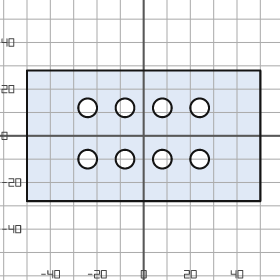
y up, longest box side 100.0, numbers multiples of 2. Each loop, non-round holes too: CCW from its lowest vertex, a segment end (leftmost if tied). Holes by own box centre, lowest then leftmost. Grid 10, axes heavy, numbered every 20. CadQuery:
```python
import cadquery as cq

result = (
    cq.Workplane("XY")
    .moveTo(-50.0, -28.0)
    .lineTo(50.0, -28.0)
    .lineTo(50.0, 28.0)
    .lineTo(-50.0, 28.0)
    .close()
    .moveTo(-24.0, -10.0)
    .circle(4.0)
    .moveTo(-8.0, -10.0)
    .circle(4.0)
    .moveTo(8.0, -10.0)
    .circle(4.0)
    .moveTo(24.0, -10.0)
    .circle(4.0)
    .moveTo(-24.0, 12.0)
    .circle(4.0)
    .moveTo(-8.0, 12.0)
    .circle(4.0)
    .moveTo(8.0, 12.0)
    .circle(4.0)
    .moveTo(24.0, 12.0)
    .circle(4.0)
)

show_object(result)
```